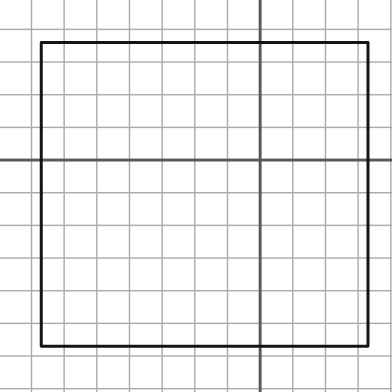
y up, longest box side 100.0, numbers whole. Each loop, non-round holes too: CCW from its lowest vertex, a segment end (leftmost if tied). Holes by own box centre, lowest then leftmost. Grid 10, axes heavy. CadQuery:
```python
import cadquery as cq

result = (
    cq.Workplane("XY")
    .moveTo(-67.0, -57.0)
    .lineTo(33.0, -57.0)
    .lineTo(33.0, 36.0)
    .lineTo(-67.0, 36.0)
    .close()
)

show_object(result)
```